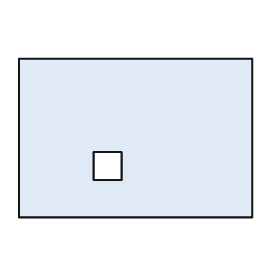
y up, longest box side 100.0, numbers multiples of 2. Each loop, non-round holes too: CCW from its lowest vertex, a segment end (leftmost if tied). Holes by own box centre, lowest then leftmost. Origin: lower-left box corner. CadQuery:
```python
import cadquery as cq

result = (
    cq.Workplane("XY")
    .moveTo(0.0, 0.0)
    .lineTo(100.0, 0.0)
    .lineTo(100.0, 68.0)
    .lineTo(0.0, 68.0)
    .close()
    .moveTo(32.0, 16.0)
    .lineTo(44.0, 16.0)
    .lineTo(44.0, 28.0)
    .lineTo(32.0, 28.0)
    .close()
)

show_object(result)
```